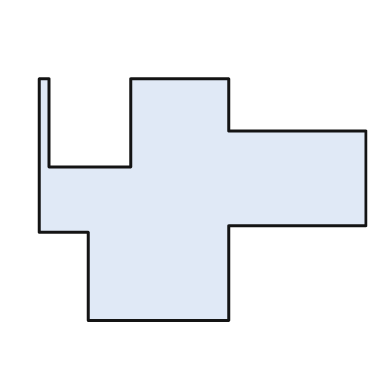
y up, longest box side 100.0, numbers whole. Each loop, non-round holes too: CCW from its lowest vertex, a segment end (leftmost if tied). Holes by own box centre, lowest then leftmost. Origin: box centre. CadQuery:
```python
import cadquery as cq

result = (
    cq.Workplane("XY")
    .moveTo(-35.0, -37.0)
    .lineTo(8.0, -37.0)
    .lineTo(8.0, -8.0)
    .lineTo(50.0, -8.0)
    .lineTo(50.0, 21.0)
    .lineTo(8.0, 21.0)
    .lineTo(8.0, 37.0)
    .lineTo(-22.0, 37.0)
    .lineTo(-22.0, 10.0)
    .lineTo(-47.0, 10.0)
    .lineTo(-47.0, 37.0)
    .lineTo(-50.0, 37.0)
    .lineTo(-50.0, -10.0)
    .lineTo(-35.0, -10.0)
    .close()
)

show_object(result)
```